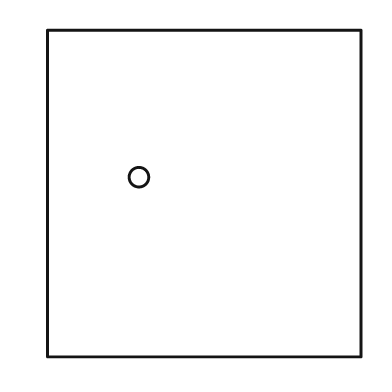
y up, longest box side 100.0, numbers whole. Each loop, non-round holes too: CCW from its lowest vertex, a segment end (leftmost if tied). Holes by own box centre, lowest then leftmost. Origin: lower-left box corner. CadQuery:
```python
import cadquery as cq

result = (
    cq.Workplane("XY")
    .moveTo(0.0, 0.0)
    .lineTo(96.0, 0.0)
    .lineTo(96.0, 100.0)
    .lineTo(0.0, 100.0)
    .close()
    .moveTo(28.0, 55.0)
    .circle(3.0)
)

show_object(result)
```